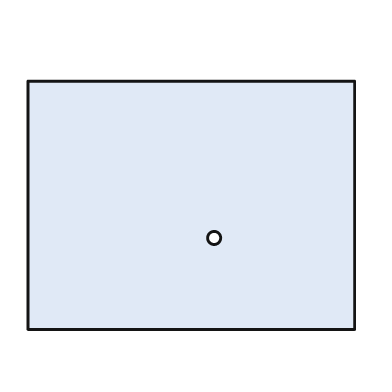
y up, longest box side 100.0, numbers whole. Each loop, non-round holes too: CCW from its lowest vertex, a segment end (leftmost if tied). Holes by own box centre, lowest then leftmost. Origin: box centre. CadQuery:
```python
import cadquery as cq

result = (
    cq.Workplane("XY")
    .moveTo(-50.0, -38.0)
    .lineTo(50.0, -38.0)
    .lineTo(50.0, 38.0)
    .lineTo(-50.0, 38.0)
    .close()
    .moveTo(7.0, -10.0)
    .circle(2.0)
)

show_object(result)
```